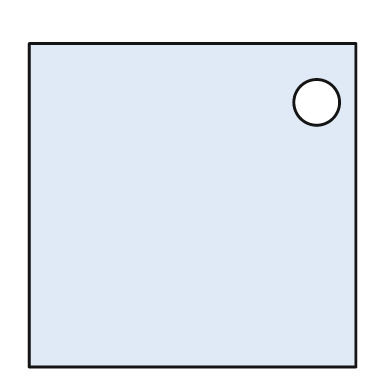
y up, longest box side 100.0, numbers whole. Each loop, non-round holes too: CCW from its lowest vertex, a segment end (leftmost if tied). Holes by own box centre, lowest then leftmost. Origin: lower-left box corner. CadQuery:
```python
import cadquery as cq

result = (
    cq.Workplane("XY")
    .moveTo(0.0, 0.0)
    .lineTo(100.0, 0.0)
    .lineTo(100.0, 99.0)
    .lineTo(0.0, 99.0)
    .close()
    .moveTo(88.0, 81.0)
    .circle(7.0)
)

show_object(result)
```